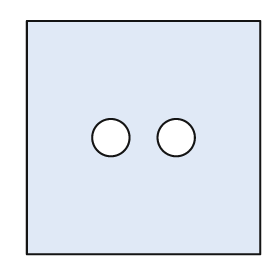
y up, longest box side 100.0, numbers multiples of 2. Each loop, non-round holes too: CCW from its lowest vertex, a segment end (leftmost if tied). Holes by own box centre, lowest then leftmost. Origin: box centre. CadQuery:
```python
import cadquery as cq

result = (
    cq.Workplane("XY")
    .moveTo(-50.0, -50.0)
    .lineTo(50.0, -50.0)
    .lineTo(50.0, 50.0)
    .lineTo(-50.0, 50.0)
    .close()
    .moveTo(-14.0, 0.0)
    .circle(8.0)
    .moveTo(14.0, 0.0)
    .circle(8.0)
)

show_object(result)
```